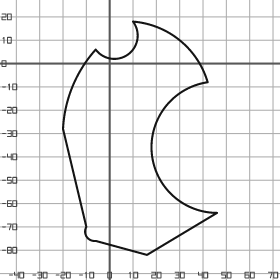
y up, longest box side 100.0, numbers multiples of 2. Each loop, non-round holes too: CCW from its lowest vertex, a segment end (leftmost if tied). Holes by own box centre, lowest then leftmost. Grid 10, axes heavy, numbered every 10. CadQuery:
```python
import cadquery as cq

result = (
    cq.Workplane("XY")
    .moveTo(16.0, -82.0)
    .lineTo(46.0, -64.0)
    .threePointArc((18.0, -38.0), (42.0, -8.0))
    .threePointArc((30.0, 10.0), (10.0, 18.0))
    .threePointArc((8.0, 4.0), (-6.0, 6.0))
    .threePointArc((-16.0, -10.0), (-20.0, -28.0))
    .lineTo(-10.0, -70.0)
    .threePointArc((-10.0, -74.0), (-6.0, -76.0))
    .close()
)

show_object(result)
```